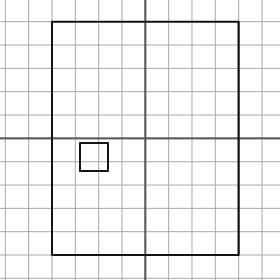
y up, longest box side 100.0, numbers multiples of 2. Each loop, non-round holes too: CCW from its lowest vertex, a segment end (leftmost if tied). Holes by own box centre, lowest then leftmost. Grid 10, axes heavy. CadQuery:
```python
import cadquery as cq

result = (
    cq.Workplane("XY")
    .moveTo(-40.0, -50.0)
    .lineTo(40.0, -50.0)
    .lineTo(40.0, 50.0)
    .lineTo(-40.0, 50.0)
    .close()
    .moveTo(-28.0, -14.0)
    .lineTo(-16.0, -14.0)
    .lineTo(-16.0, -2.0)
    .lineTo(-28.0, -2.0)
    .close()
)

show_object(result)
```